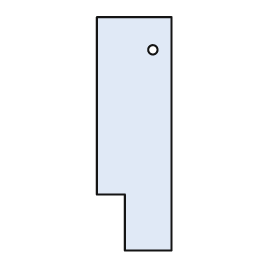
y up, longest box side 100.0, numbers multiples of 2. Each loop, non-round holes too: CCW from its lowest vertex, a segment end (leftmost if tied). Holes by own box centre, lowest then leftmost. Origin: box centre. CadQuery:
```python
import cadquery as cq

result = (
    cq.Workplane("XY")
    .moveTo(-4.0, -50.0)
    .lineTo(16.0, -50.0)
    .lineTo(16.0, 50.0)
    .lineTo(-16.0, 50.0)
    .lineTo(-16.0, -26.0)
    .lineTo(-4.0, -26.0)
    .close()
    .moveTo(8.0, 36.0)
    .circle(2.0)
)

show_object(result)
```